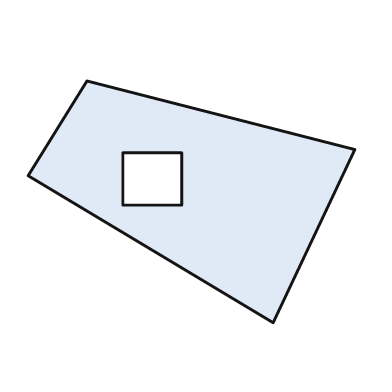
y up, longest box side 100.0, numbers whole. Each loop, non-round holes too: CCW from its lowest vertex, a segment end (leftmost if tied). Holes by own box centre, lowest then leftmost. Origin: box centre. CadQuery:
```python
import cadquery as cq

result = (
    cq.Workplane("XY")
    .moveTo(25.0, -37.0)
    .lineTo(50.0, 16.0)
    .lineTo(-32.0, 37.0)
    .lineTo(-50.0, 8.0)
    .close()
    .moveTo(-21.0, -1.0)
    .lineTo(-3.0, -1.0)
    .lineTo(-3.0, 15.0)
    .lineTo(-21.0, 15.0)
    .close()
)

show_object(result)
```